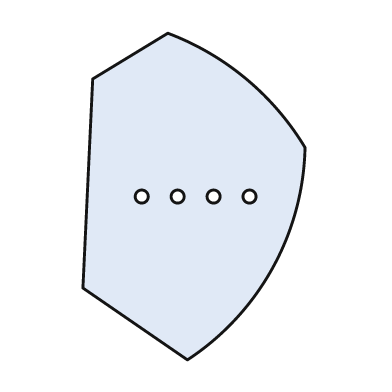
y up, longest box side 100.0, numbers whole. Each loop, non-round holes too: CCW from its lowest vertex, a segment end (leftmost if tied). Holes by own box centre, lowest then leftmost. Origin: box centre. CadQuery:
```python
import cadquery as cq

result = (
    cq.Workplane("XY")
    .moveTo(-2.0, -50.0)
    .threePointArc((24.0, -22.0), (34.0, 15.0))
    .threePointArc((16.0, 36.0), (-8.0, 50.0))
    .lineTo(-31.0, 36.0)
    .lineTo(-34.0, -28.0)
    .close()
    .moveTo(-16.0, 0.0)
    .circle(2.0)
    .moveTo(-5.0, 0.0)
    .circle(2.0)
    .moveTo(6.0, 0.0)
    .circle(2.0)
    .moveTo(17.0, 0.0)
    .circle(2.0)
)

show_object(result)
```